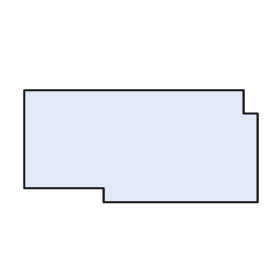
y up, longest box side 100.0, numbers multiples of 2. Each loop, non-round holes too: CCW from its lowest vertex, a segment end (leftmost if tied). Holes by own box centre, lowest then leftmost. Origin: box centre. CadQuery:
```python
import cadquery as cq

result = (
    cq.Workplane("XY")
    .moveTo(-16.0, -24.0)
    .lineTo(50.0, -24.0)
    .lineTo(50.0, 14.0)
    .lineTo(44.0, 14.0)
    .lineTo(44.0, 24.0)
    .lineTo(-50.0, 24.0)
    .lineTo(-50.0, -18.0)
    .lineTo(-16.0, -18.0)
    .close()
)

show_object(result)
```